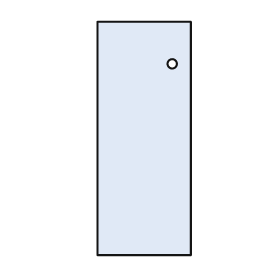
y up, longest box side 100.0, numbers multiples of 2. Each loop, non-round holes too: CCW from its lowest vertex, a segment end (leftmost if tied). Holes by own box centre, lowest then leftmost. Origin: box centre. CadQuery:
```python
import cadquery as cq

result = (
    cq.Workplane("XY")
    .moveTo(-20.0, -50.0)
    .lineTo(20.0, -50.0)
    .lineTo(20.0, 50.0)
    .lineTo(-20.0, 50.0)
    .close()
    .moveTo(12.0, 32.0)
    .circle(2.0)
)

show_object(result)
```